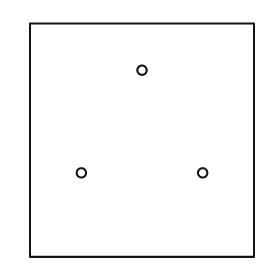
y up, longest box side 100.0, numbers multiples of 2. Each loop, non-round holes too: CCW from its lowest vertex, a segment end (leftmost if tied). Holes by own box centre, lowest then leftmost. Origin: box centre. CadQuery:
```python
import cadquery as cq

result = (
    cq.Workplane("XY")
    .moveTo(-48.0, -50.0)
    .lineTo(48.0, -50.0)
    .lineTo(48.0, 50.0)
    .lineTo(-48.0, 50.0)
    .close()
    .moveTo(-26.0, -14.0)
    .circle(2.0)
    .moveTo(26.0, -14.0)
    .circle(2.0)
    .moveTo(0.0, 30.0)
    .circle(2.0)
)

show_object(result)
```